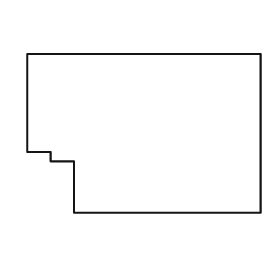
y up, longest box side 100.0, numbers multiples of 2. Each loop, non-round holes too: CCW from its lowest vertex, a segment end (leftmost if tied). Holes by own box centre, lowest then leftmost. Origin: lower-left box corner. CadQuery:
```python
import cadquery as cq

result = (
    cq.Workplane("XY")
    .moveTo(20.0, 0.0)
    .lineTo(100.0, 0.0)
    .lineTo(100.0, 68.0)
    .lineTo(0.0, 68.0)
    .lineTo(0.0, 26.0)
    .lineTo(10.0, 26.0)
    .lineTo(10.0, 22.0)
    .lineTo(20.0, 22.0)
    .close()
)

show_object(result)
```